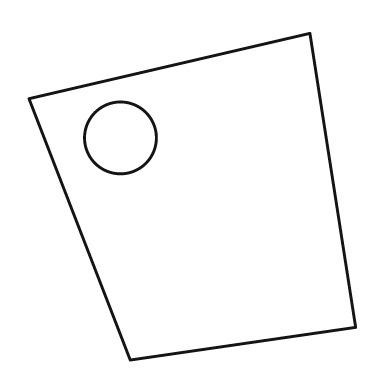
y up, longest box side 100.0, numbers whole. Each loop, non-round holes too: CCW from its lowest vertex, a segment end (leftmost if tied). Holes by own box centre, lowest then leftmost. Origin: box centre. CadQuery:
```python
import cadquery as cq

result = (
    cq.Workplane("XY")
    .moveTo(-19.0, -50.0)
    .lineTo(50.0, -40.0)
    .lineTo(36.0, 50.0)
    .lineTo(-50.0, 30.0)
    .close()
    .moveTo(-22.0, 18.0)
    .circle(11.0)
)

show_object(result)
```